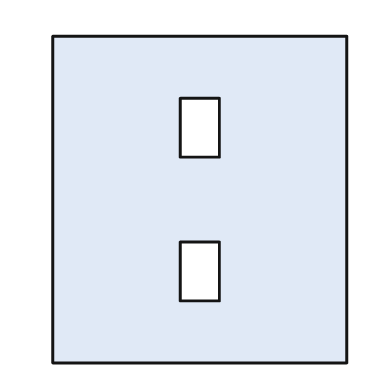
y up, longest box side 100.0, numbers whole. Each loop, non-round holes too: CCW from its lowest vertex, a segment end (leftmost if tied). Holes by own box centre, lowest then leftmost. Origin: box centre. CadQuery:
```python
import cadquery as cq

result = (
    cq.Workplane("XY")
    .moveTo(-45.0, -50.0)
    .lineTo(45.0, -50.0)
    .lineTo(45.0, 50.0)
    .lineTo(-45.0, 50.0)
    .close()
    .moveTo(-6.0, -31.0)
    .lineTo(6.0, -31.0)
    .lineTo(6.0, -13.0)
    .lineTo(-6.0, -13.0)
    .close()
    .moveTo(-6.0, 13.0)
    .lineTo(6.0, 13.0)
    .lineTo(6.0, 31.0)
    .lineTo(-6.0, 31.0)
    .close()
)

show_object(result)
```